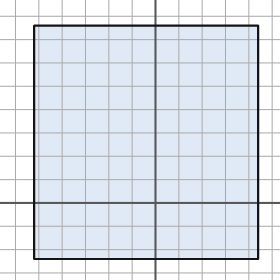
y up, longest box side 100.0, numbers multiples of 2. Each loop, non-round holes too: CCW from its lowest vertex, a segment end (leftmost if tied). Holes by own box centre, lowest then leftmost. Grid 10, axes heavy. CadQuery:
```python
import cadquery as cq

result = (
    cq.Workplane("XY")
    .moveTo(-52.0, -24.0)
    .lineTo(44.0, -24.0)
    .lineTo(44.0, 76.0)
    .lineTo(-52.0, 76.0)
    .close()
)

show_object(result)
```